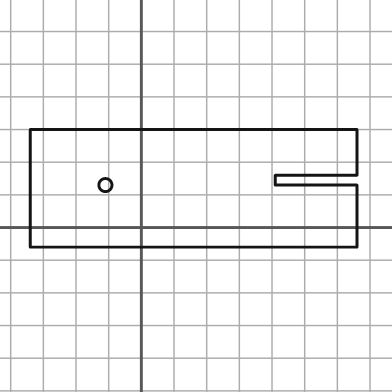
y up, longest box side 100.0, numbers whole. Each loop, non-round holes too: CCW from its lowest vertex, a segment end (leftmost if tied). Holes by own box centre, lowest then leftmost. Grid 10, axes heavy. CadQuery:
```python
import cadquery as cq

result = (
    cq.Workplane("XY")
    .moveTo(-34.0, -6.0)
    .lineTo(66.0, -6.0)
    .lineTo(66.0, 13.0)
    .lineTo(41.0, 13.0)
    .lineTo(41.0, 16.0)
    .lineTo(66.0, 16.0)
    .lineTo(66.0, 30.0)
    .lineTo(-34.0, 30.0)
    .close()
    .moveTo(-11.0, 13.0)
    .circle(2.0)
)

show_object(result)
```